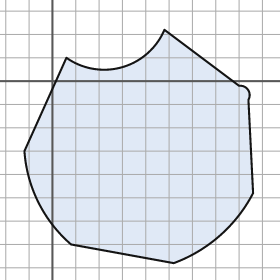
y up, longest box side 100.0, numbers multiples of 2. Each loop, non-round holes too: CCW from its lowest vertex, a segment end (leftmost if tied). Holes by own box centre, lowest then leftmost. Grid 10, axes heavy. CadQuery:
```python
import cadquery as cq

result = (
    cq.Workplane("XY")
    .moveTo(52.0, -78.0)
    .threePointArc((72.0, -66.0), (86.0, -48.0))
    .lineTo(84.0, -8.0)
    .threePointArc((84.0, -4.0), (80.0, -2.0))
    .lineTo(48.0, 22.0)
    .threePointArc((30.0, 6.0), (6.0, 10.0))
    .lineTo(-12.0, -30.0)
    .threePointArc((-6.0, -52.0), (8.0, -70.0))
    .close()
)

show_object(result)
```